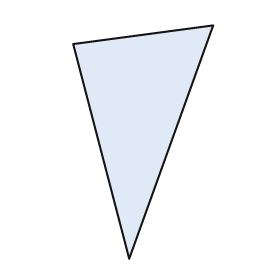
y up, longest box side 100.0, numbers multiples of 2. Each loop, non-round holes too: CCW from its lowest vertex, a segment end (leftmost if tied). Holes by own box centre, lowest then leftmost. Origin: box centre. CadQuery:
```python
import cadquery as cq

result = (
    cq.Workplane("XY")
    .moveTo(-6.0, -50.0)
    .lineTo(30.0, 50.0)
    .lineTo(-30.0, 42.0)
    .close()
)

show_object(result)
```